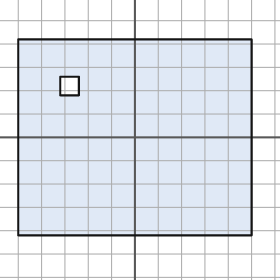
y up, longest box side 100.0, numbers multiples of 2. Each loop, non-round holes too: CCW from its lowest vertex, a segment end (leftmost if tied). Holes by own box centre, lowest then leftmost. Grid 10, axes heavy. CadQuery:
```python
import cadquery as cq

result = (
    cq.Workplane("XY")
    .moveTo(-50.0, -42.0)
    .lineTo(50.0, -42.0)
    .lineTo(50.0, 42.0)
    .lineTo(-50.0, 42.0)
    .close()
    .moveTo(-32.0, 18.0)
    .lineTo(-24.0, 18.0)
    .lineTo(-24.0, 26.0)
    .lineTo(-32.0, 26.0)
    .close()
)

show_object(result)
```